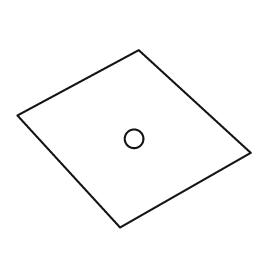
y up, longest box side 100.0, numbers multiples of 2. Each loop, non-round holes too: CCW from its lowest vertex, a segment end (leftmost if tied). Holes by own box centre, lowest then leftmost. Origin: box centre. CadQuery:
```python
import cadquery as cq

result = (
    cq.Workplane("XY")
    .moveTo(-6.0, -38.0)
    .lineTo(50.0, -6.0)
    .lineTo(2.0, 38.0)
    .lineTo(-50.0, 10.0)
    .close()
    .moveTo(0.0, 0.0)
    .circle(4.0)
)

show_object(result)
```